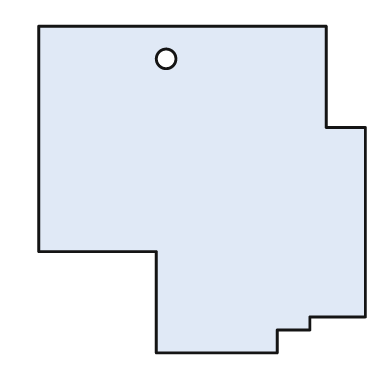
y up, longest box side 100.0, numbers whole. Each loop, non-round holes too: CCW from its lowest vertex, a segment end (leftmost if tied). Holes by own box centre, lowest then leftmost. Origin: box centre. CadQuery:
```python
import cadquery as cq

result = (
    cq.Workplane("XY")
    .moveTo(-14.0, -50.0)
    .lineTo(23.0, -50.0)
    .lineTo(23.0, -43.0)
    .lineTo(33.0, -43.0)
    .lineTo(33.0, -39.0)
    .lineTo(50.0, -39.0)
    .lineTo(50.0, 19.0)
    .lineTo(38.0, 19.0)
    .lineTo(38.0, 50.0)
    .lineTo(-50.0, 50.0)
    .lineTo(-50.0, -19.0)
    .lineTo(-14.0, -19.0)
    .close()
    .moveTo(-11.0, 40.0)
    .circle(3.0)
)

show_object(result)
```